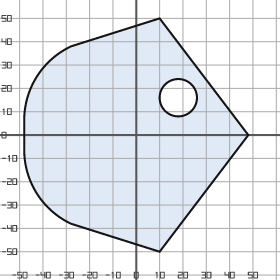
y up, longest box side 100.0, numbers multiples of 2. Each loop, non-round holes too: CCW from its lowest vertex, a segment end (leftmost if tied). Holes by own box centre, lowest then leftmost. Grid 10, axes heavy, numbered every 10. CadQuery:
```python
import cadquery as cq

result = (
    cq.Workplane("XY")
    .moveTo(10.0, -50.0)
    .lineTo(48.0, 0.0)
    .lineTo(10.0, 50.0)
    .lineTo(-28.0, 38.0)
    .threePointArc((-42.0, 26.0), (-48.0, 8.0))
    .lineTo(-48.0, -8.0)
    .threePointArc((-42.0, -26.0), (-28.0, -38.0))
    .close()
    .moveTo(18.0, 16.0)
    .circle(8.0)
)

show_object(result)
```